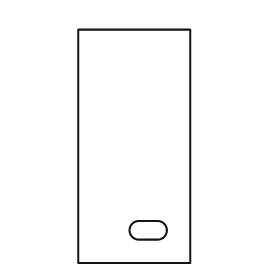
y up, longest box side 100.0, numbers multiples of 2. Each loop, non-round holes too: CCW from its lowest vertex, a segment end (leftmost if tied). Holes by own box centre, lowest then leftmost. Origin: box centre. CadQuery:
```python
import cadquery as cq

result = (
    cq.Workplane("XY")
    .moveTo(-24.0, -50.0)
    .lineTo(24.0, -50.0)
    .lineTo(24.0, 50.0)
    .lineTo(-24.0, 50.0)
    .close()
    .moveTo(2.0, -40.0)
    .lineTo(10.0, -40.0)
    .threePointArc((14.0, -36.0), (10.0, -32.0))
    .lineTo(2.0, -32.0)
    .threePointArc((-2.0, -36.0), (2.0, -40.0))
    .close()
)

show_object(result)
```